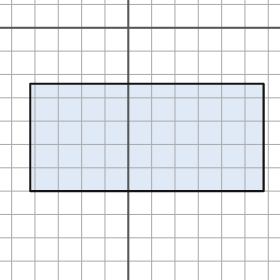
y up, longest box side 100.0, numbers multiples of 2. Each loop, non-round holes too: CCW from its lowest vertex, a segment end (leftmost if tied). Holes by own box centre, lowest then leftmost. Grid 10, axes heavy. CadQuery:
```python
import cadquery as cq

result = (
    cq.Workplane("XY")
    .moveTo(-42.0, -70.0)
    .lineTo(58.0, -70.0)
    .lineTo(58.0, -24.0)
    .lineTo(-42.0, -24.0)
    .close()
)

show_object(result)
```